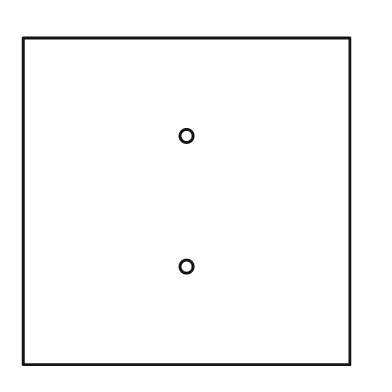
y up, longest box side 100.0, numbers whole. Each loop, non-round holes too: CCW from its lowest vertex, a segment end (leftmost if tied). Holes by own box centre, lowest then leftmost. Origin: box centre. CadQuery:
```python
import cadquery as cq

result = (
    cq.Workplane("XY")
    .moveTo(-50.0, -50.0)
    .lineTo(50.0, -50.0)
    .lineTo(50.0, 50.0)
    .lineTo(-50.0, 50.0)
    .close()
    .moveTo(0.0, -20.0)
    .circle(2.0)
    .moveTo(0.0, 20.0)
    .circle(2.0)
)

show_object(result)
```